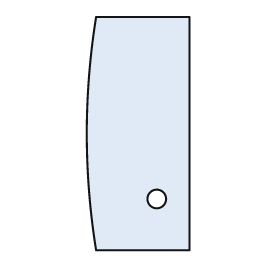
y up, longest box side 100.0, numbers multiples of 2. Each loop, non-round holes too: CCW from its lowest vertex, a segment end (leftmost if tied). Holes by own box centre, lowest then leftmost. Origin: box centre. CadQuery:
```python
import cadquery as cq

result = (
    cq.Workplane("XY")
    .moveTo(-18.0, -50.0)
    .lineTo(22.0, -50.0)
    .lineTo(22.0, 50.0)
    .lineTo(-18.0, 50.0)
    .threePointArc((-22.0, 0.0), (-18.0, -50.0))
    .close()
    .moveTo(8.0, -28.0)
    .circle(4.0)
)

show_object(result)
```